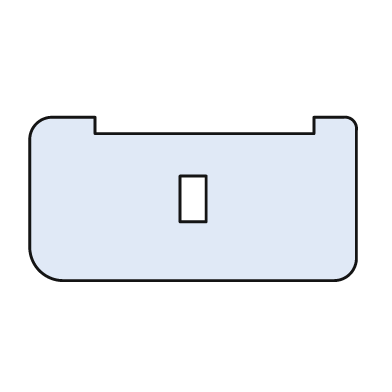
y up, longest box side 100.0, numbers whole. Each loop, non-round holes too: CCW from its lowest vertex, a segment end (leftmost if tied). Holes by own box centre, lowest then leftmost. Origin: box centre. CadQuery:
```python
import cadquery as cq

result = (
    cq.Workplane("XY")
    .moveTo(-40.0, -25.0)
    .lineTo(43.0, -25.0)
    .threePointArc((48.0, -23.0), (50.0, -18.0))
    .lineTo(50.0, 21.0)
    .threePointArc((49.0, 24.0), (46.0, 25.0))
    .lineTo(37.0, 25.0)
    .lineTo(37.0, 20.0)
    .lineTo(-30.0, 20.0)
    .lineTo(-30.0, 25.0)
    .lineTo(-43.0, 25.0)
    .threePointArc((-48.0, 23.0), (-50.0, 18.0))
    .lineTo(-50.0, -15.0)
    .threePointArc((-47.0, -22.0), (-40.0, -25.0))
    .close()
    .moveTo(-4.0, -7.0)
    .lineTo(4.0, -7.0)
    .lineTo(4.0, 7.0)
    .lineTo(-4.0, 7.0)
    .close()
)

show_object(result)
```